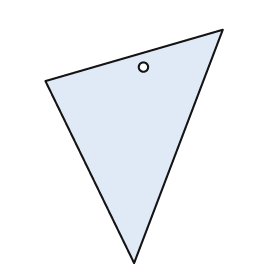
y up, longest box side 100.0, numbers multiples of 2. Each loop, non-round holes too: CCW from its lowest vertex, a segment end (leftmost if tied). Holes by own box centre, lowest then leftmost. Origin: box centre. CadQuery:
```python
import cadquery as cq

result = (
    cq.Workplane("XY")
    .moveTo(0.0, -50.0)
    .lineTo(38.0, 50.0)
    .lineTo(-38.0, 28.0)
    .close()
    .moveTo(4.0, 34.0)
    .circle(2.0)
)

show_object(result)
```